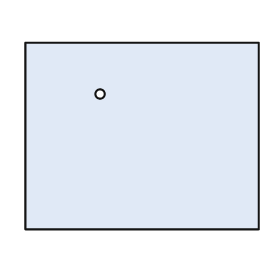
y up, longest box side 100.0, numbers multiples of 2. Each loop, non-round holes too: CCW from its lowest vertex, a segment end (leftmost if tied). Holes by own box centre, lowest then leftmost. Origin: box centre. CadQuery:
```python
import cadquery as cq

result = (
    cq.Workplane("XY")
    .moveTo(-50.0, -40.0)
    .lineTo(50.0, -40.0)
    .lineTo(50.0, 40.0)
    .lineTo(-50.0, 40.0)
    .close()
    .moveTo(-18.0, 18.0)
    .circle(2.0)
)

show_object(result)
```